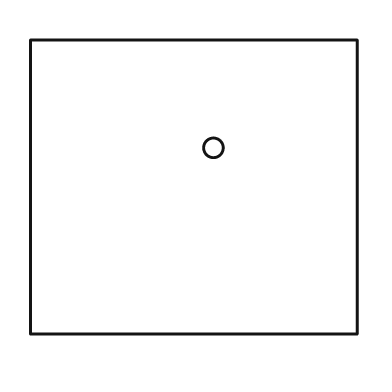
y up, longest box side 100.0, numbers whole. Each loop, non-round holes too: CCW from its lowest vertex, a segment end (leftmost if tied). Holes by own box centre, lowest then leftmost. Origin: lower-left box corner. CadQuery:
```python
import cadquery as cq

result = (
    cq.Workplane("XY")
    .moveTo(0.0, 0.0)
    .lineTo(100.0, 0.0)
    .lineTo(100.0, 90.0)
    .lineTo(0.0, 90.0)
    .close()
    .moveTo(56.0, 57.0)
    .circle(3.0)
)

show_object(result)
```